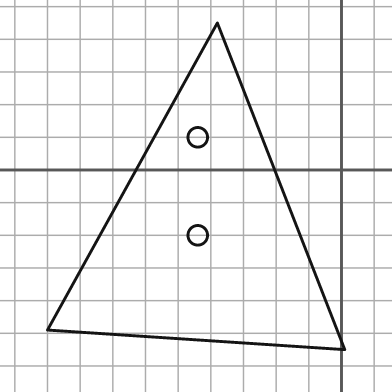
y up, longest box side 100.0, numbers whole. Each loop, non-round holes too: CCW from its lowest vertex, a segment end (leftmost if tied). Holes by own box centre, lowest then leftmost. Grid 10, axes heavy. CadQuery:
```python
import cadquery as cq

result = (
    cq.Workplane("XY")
    .moveTo(1.0, -55.0)
    .lineTo(-38.0, 45.0)
    .lineTo(-90.0, -49.0)
    .close()
    .moveTo(-44.0, -20.0)
    .circle(3.0)
    .moveTo(-44.0, 10.0)
    .circle(3.0)
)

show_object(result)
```